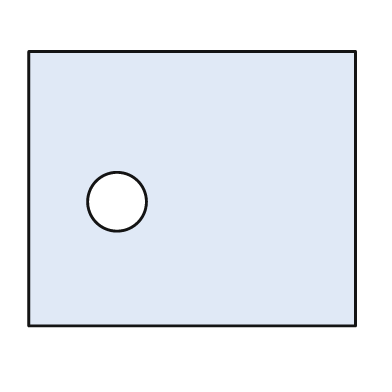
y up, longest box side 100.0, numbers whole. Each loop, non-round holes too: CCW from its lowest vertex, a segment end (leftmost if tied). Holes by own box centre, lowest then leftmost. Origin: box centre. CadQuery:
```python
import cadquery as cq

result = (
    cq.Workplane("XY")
    .moveTo(-50.0, -42.0)
    .lineTo(50.0, -42.0)
    .lineTo(50.0, 42.0)
    .lineTo(-50.0, 42.0)
    .close()
    .moveTo(-23.0, -4.0)
    .circle(9.0)
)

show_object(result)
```